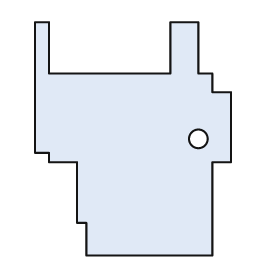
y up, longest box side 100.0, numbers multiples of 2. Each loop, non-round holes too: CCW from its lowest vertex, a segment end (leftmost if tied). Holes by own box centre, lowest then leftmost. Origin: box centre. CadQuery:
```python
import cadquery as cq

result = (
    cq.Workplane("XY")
    .moveTo(-20.0, -50.0)
    .lineTo(34.0, -50.0)
    .lineTo(34.0, -10.0)
    .lineTo(42.0, -10.0)
    .lineTo(42.0, 20.0)
    .lineTo(34.0, 20.0)
    .lineTo(34.0, 28.0)
    .lineTo(28.0, 28.0)
    .lineTo(28.0, 50.0)
    .lineTo(16.0, 50.0)
    .lineTo(16.0, 28.0)
    .lineTo(-36.0, 28.0)
    .lineTo(-36.0, 50.0)
    .lineTo(-42.0, 50.0)
    .lineTo(-42.0, -6.0)
    .lineTo(-36.0, -6.0)
    .lineTo(-36.0, -10.0)
    .lineTo(-24.0, -10.0)
    .lineTo(-24.0, -36.0)
    .lineTo(-20.0, -36.0)
    .close()
    .moveTo(28.0, 0.0)
    .circle(4.0)
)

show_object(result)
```